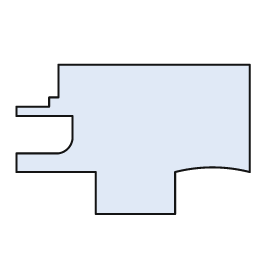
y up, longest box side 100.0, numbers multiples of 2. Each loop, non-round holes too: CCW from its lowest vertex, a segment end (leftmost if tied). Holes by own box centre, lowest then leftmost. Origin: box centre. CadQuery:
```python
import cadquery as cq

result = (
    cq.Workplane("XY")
    .moveTo(-16.0, -32.0)
    .lineTo(18.0, -32.0)
    .lineTo(18.0, -14.0)
    .threePointArc((34.0, -12.0), (50.0, -14.0))
    .lineTo(50.0, 32.0)
    .lineTo(-32.0, 32.0)
    .lineTo(-32.0, 18.0)
    .lineTo(-36.0, 18.0)
    .lineTo(-36.0, 14.0)
    .lineTo(-50.0, 14.0)
    .lineTo(-50.0, 10.0)
    .lineTo(-26.0, 10.0)
    .lineTo(-26.0, 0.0)
    .threePointArc((-28.0, -4.0), (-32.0, -6.0))
    .lineTo(-50.0, -6.0)
    .lineTo(-50.0, -14.0)
    .lineTo(-16.0, -14.0)
    .close()
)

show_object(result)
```